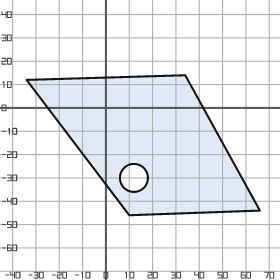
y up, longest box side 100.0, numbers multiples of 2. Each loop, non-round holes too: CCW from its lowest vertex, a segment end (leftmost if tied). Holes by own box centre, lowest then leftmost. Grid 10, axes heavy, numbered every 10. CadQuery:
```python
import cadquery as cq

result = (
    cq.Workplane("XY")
    .moveTo(10.0, -46.0)
    .lineTo(66.0, -44.0)
    .lineTo(34.0, 14.0)
    .lineTo(-34.0, 12.0)
    .close()
    .moveTo(12.0, -30.0)
    .circle(6.0)
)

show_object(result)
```